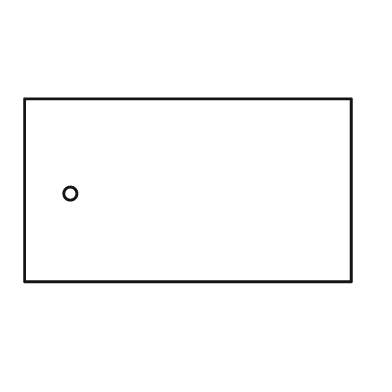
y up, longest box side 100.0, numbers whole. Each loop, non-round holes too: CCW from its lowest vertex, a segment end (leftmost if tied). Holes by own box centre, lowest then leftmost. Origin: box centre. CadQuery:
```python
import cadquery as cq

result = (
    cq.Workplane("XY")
    .moveTo(-50.0, -28.0)
    .lineTo(50.0, -28.0)
    .lineTo(50.0, 28.0)
    .lineTo(-50.0, 28.0)
    .close()
    .moveTo(-36.0, -1.0)
    .circle(2.0)
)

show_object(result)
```